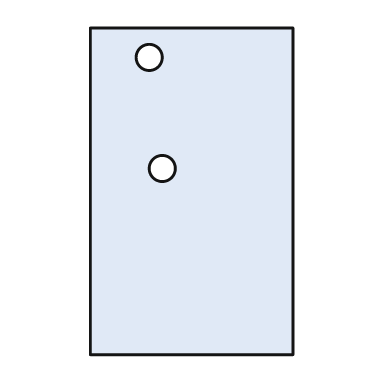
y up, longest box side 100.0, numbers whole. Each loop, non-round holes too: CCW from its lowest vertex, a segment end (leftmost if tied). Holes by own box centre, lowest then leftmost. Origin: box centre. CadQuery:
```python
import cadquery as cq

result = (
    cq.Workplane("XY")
    .moveTo(-31.0, -50.0)
    .lineTo(31.0, -50.0)
    .lineTo(31.0, 50.0)
    .lineTo(-31.0, 50.0)
    .close()
    .moveTo(-9.0, 7.0)
    .circle(4.0)
    .moveTo(-13.0, 41.0)
    .circle(4.0)
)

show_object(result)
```